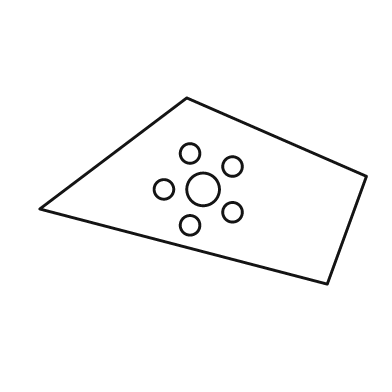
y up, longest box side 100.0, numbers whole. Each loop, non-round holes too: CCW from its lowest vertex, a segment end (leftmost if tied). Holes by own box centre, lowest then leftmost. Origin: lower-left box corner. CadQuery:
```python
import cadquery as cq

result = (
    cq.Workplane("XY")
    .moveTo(88.0, 0.0)
    .lineTo(100.0, 33.0)
    .lineTo(45.0, 57.0)
    .lineTo(0.0, 23.0)
    .close()
    .moveTo(46.0, 18.0)
    .circle(3.0)
    .moveTo(59.0, 22.0)
    .circle(3.0)
    .moveTo(38.0, 29.0)
    .circle(3.0)
    .moveTo(50.0, 29.0)
    .circle(5.0)
    .moveTo(59.0, 36.0)
    .circle(3.0)
    .moveTo(46.0, 40.0)
    .circle(3.0)
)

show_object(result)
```